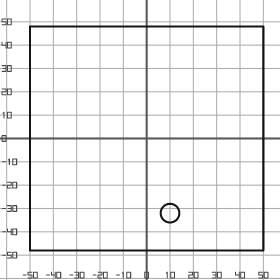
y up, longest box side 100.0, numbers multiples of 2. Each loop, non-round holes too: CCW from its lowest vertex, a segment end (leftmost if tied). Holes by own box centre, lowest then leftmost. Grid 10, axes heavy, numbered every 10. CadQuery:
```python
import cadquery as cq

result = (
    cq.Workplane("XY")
    .moveTo(-50.0, -48.0)
    .lineTo(50.0, -48.0)
    .lineTo(50.0, 48.0)
    .lineTo(-50.0, 48.0)
    .close()
    .moveTo(10.0, -32.0)
    .circle(4.0)
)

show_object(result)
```